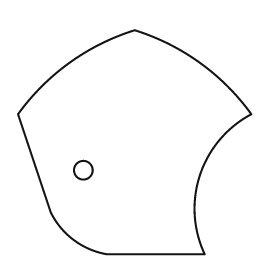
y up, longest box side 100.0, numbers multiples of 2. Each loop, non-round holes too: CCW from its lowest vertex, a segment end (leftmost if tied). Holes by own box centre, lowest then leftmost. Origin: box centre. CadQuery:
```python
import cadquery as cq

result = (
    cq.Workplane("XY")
    .moveTo(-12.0, -48.0)
    .lineTo(30.0, -48.0)
    .threePointArc((28.0, -14.0), (50.0, 12.0))
    .threePointArc((28.0, 34.0), (0.0, 48.0))
    .threePointArc((-28.0, 34.0), (-50.0, 12.0))
    .lineTo(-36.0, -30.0)
    .threePointArc((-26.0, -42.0), (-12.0, -48.0))
    .close()
    .moveTo(-22.0, -12.0)
    .circle(4.0)
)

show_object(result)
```